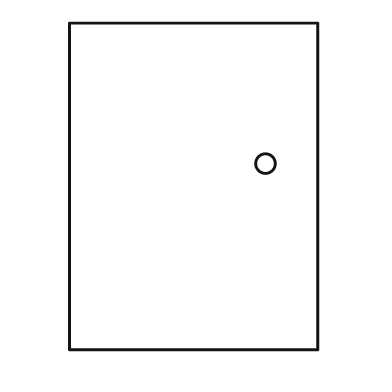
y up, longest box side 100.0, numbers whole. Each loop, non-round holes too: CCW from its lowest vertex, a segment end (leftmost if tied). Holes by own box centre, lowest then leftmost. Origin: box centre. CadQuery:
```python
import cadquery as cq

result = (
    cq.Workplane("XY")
    .moveTo(-38.0, -50.0)
    .lineTo(38.0, -50.0)
    .lineTo(38.0, 50.0)
    .lineTo(-38.0, 50.0)
    .close()
    .moveTo(22.0, 7.0)
    .circle(3.0)
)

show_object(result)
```